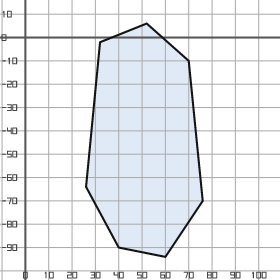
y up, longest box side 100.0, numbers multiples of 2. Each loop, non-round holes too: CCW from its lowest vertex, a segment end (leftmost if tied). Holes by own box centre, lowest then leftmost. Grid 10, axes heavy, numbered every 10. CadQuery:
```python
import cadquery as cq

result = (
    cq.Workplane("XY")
    .moveTo(60.0, -94.0)
    .lineTo(76.0, -70.0)
    .lineTo(70.0, -10.0)
    .lineTo(52.0, 6.0)
    .lineTo(32.0, -2.0)
    .lineTo(26.0, -64.0)
    .lineTo(40.0, -90.0)
    .close()
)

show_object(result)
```